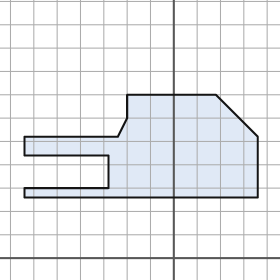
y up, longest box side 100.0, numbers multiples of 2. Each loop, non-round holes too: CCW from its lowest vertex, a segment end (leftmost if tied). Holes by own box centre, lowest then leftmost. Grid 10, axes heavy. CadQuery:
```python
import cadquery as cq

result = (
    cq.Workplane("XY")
    .moveTo(-64.0, 26.0)
    .lineTo(36.0, 26.0)
    .lineTo(36.0, 52.0)
    .lineTo(18.0, 70.0)
    .lineTo(-20.0, 70.0)
    .lineTo(-20.0, 60.0)
    .lineTo(-24.0, 52.0)
    .lineTo(-64.0, 52.0)
    .lineTo(-64.0, 44.0)
    .lineTo(-28.0, 44.0)
    .lineTo(-28.0, 30.0)
    .lineTo(-64.0, 30.0)
    .close()
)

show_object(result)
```